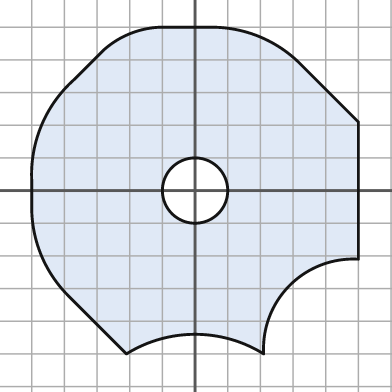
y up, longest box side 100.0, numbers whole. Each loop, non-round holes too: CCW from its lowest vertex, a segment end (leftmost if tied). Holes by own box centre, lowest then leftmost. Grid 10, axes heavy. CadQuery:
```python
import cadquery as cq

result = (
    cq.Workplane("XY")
    .moveTo(-21.0, -50.0)
    .threePointArc((0.0, -44.0), (21.0, -50.0))
    .threePointArc((29.0, -29.0), (50.0, -21.0))
    .lineTo(50.0, 21.0)
    .lineTo(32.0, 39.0)
    .threePointArc((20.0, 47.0), (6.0, 50.0))
    .lineTo(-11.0, 50.0)
    .threePointArc((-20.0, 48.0), (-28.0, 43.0))
    .lineTo(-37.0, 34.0)
    .threePointArc((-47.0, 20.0), (-50.0, 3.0))
    .lineTo(-50.0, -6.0)
    .threePointArc((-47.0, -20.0), (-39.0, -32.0))
    .close()
    .moveTo(0.0, 0.0)
    .circle(10.0)
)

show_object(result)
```